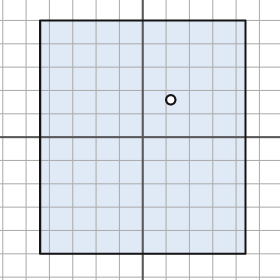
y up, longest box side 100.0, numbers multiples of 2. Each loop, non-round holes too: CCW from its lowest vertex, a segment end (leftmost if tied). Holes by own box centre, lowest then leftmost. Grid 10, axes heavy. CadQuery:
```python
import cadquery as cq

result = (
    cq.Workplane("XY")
    .moveTo(-44.0, -50.0)
    .lineTo(44.0, -50.0)
    .lineTo(44.0, 50.0)
    .lineTo(-44.0, 50.0)
    .close()
    .moveTo(12.0, 16.0)
    .circle(2.0)
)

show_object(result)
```